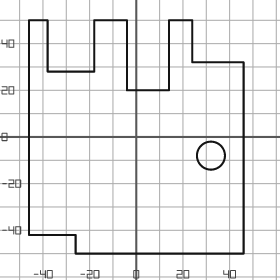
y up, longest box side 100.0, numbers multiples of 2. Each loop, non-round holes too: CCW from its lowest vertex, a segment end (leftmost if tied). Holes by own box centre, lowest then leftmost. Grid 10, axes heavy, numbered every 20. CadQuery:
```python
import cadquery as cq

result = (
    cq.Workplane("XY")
    .moveTo(-26.0, -50.0)
    .lineTo(46.0, -50.0)
    .lineTo(46.0, 32.0)
    .lineTo(24.0, 32.0)
    .lineTo(24.0, 50.0)
    .lineTo(14.0, 50.0)
    .lineTo(14.0, 20.0)
    .lineTo(-4.0, 20.0)
    .lineTo(-4.0, 50.0)
    .lineTo(-18.0, 50.0)
    .lineTo(-18.0, 28.0)
    .lineTo(-38.0, 28.0)
    .lineTo(-38.0, 50.0)
    .lineTo(-46.0, 50.0)
    .lineTo(-46.0, -42.0)
    .lineTo(-26.0, -42.0)
    .close()
    .moveTo(32.0, -8.0)
    .circle(6.0)
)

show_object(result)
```